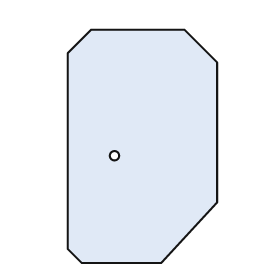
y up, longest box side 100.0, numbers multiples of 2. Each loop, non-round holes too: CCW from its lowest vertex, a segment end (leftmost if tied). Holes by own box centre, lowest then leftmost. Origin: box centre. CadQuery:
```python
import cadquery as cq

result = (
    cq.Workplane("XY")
    .moveTo(-26.0, -50.0)
    .lineTo(8.0, -50.0)
    .lineTo(32.0, -24.0)
    .lineTo(32.0, 36.0)
    .lineTo(18.0, 50.0)
    .lineTo(-22.0, 50.0)
    .lineTo(-32.0, 40.0)
    .lineTo(-32.0, -44.0)
    .close()
    .moveTo(-12.0, -4.0)
    .circle(2.0)
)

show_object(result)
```